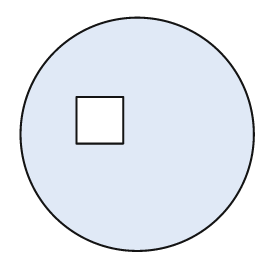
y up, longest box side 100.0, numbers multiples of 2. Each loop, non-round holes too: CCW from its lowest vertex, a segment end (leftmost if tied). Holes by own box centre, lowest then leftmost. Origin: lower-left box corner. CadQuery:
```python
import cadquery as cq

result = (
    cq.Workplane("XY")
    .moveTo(50.0, 50.0)
    .circle(50.0)
    .moveTo(24.0, 46.0)
    .lineTo(44.0, 46.0)
    .lineTo(44.0, 66.0)
    .lineTo(24.0, 66.0)
    .close()
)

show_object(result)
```